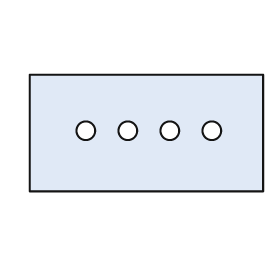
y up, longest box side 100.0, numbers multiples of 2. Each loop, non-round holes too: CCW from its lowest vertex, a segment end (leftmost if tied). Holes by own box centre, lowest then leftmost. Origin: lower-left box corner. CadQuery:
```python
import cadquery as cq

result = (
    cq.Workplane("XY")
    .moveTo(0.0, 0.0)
    .lineTo(100.0, 0.0)
    .lineTo(100.0, 50.0)
    .lineTo(0.0, 50.0)
    .close()
    .moveTo(24.0, 26.0)
    .circle(4.0)
    .moveTo(42.0, 26.0)
    .circle(4.0)
    .moveTo(60.0, 26.0)
    .circle(4.0)
    .moveTo(78.0, 26.0)
    .circle(4.0)
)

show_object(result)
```